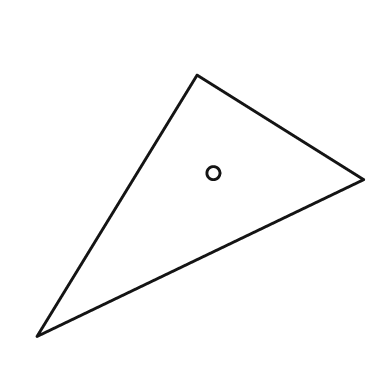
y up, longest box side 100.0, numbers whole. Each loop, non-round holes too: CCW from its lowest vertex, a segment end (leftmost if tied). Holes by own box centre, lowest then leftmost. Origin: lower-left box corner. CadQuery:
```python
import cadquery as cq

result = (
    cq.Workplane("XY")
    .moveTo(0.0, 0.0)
    .lineTo(100.0, 48.0)
    .lineTo(49.0, 80.0)
    .close()
    .moveTo(54.0, 50.0)
    .circle(2.0)
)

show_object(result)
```